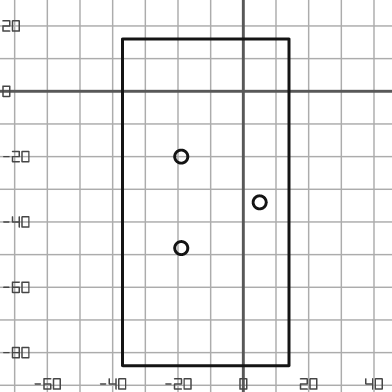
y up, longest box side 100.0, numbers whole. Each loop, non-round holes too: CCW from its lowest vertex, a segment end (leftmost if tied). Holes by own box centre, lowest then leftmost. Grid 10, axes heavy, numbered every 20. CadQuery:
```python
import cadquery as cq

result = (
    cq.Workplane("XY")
    .moveTo(-37.0, -84.0)
    .lineTo(14.0, -84.0)
    .lineTo(14.0, 16.0)
    .lineTo(-37.0, 16.0)
    .close()
    .moveTo(-19.0, -48.0)
    .circle(2.0)
    .moveTo(5.0, -34.0)
    .circle(2.0)
    .moveTo(-19.0, -20.0)
    .circle(2.0)
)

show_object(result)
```